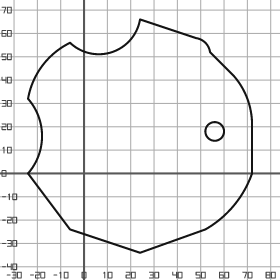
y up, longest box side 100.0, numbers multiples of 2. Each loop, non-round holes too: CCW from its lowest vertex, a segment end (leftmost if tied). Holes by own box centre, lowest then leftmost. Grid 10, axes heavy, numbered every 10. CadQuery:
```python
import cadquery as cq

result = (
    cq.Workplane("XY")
    .moveTo(24.0, -34.0)
    .lineTo(52.0, -24.0)
    .threePointArc((64.0, -14.0), (72.0, 0.0))
    .lineTo(72.0, 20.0)
    .threePointArc((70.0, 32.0), (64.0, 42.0))
    .lineTo(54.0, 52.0)
    .threePointArc((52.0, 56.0), (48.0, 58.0))
    .lineTo(24.0, 66.0)
    .threePointArc((12.0, 52.0), (-6.0, 56.0))
    .threePointArc((-18.0, 46.0), (-24.0, 32.0))
    .threePointArc((-18.0, 16.0), (-24.0, 0.0))
    .lineTo(-6.0, -24.0)
    .close()
    .moveTo(56.0, 18.0)
    .circle(4.0)
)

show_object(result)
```